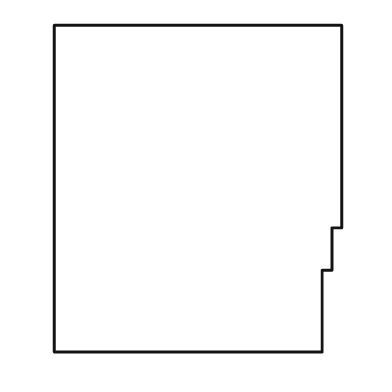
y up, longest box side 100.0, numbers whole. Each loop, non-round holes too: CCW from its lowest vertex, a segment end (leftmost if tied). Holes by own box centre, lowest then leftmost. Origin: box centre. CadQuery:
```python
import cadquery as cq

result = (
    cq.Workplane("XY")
    .moveTo(-44.0, -50.0)
    .lineTo(38.0, -50.0)
    .lineTo(38.0, -25.0)
    .lineTo(41.0, -25.0)
    .lineTo(41.0, -12.0)
    .lineTo(44.0, -12.0)
    .lineTo(44.0, 50.0)
    .lineTo(-44.0, 50.0)
    .close()
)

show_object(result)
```